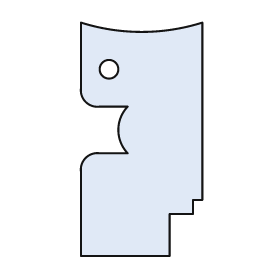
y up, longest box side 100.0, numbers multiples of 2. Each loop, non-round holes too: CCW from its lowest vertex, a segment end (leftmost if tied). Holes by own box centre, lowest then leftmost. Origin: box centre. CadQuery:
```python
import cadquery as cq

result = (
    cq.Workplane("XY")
    .moveTo(-26.0, -50.0)
    .lineTo(12.0, -50.0)
    .lineTo(12.0, -32.0)
    .lineTo(22.0, -32.0)
    .lineTo(22.0, -26.0)
    .lineTo(26.0, -26.0)
    .lineTo(26.0, 50.0)
    .threePointArc((0.0, 46.0), (-26.0, 50.0))
    .lineTo(-26.0, 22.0)
    .threePointArc((-24.0, 16.0), (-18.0, 14.0))
    .lineTo(-6.0, 14.0)
    .threePointArc((-10.0, 4.0), (-6.0, -6.0))
    .lineTo(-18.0, -6.0)
    .threePointArc((-24.0, -8.0), (-26.0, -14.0))
    .close()
    .moveTo(-14.0, 30.0)
    .circle(4.0)
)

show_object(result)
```